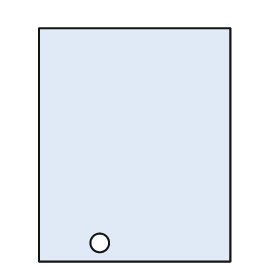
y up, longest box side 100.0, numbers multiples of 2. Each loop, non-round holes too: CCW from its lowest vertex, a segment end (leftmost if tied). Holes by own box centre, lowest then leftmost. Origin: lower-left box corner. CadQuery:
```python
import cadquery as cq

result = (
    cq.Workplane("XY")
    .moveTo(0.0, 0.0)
    .lineTo(82.0, 0.0)
    .lineTo(82.0, 100.0)
    .lineTo(0.0, 100.0)
    .close()
    .moveTo(26.0, 8.0)
    .circle(4.0)
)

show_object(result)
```